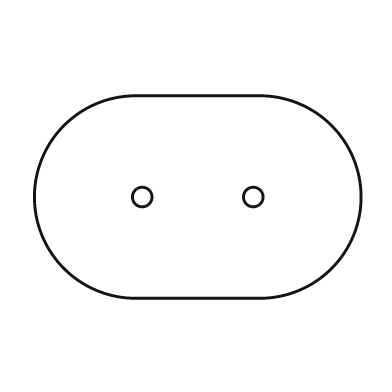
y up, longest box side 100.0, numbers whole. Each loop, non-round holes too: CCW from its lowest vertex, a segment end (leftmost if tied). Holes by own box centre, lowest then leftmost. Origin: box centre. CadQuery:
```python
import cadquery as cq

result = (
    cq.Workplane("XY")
    .moveTo(-19.0, -31.0)
    .lineTo(19.0, -31.0)
    .threePointArc((50.0, 0.0), (19.0, 31.0))
    .lineTo(-19.0, 31.0)
    .threePointArc((-50.0, 0.0), (-19.0, -31.0))
    .close()
    .moveTo(-17.0, 0.0)
    .circle(3.0)
    .moveTo(17.0, 0.0)
    .circle(3.0)
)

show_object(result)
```